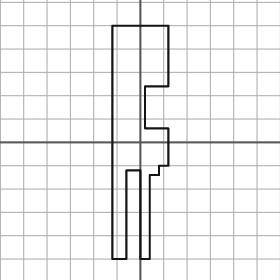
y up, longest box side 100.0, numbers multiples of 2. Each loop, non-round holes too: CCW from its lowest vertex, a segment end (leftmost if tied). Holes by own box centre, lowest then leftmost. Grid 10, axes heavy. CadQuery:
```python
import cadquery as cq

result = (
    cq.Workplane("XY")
    .moveTo(-12.0, -50.0)
    .lineTo(-6.0, -50.0)
    .lineTo(-6.0, -12.0)
    .lineTo(0.0, -12.0)
    .lineTo(0.0, -50.0)
    .lineTo(4.0, -50.0)
    .lineTo(4.0, -14.0)
    .lineTo(8.0, -14.0)
    .lineTo(8.0, -10.0)
    .lineTo(12.0, -10.0)
    .lineTo(12.0, 6.0)
    .lineTo(2.0, 6.0)
    .lineTo(2.0, 24.0)
    .lineTo(12.0, 24.0)
    .lineTo(12.0, 50.0)
    .lineTo(-12.0, 50.0)
    .close()
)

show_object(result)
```